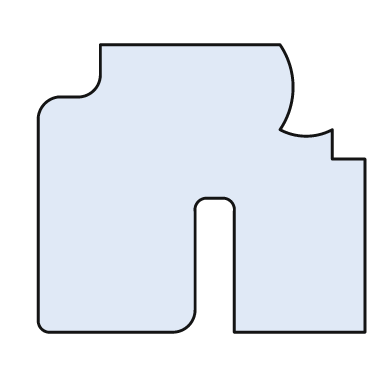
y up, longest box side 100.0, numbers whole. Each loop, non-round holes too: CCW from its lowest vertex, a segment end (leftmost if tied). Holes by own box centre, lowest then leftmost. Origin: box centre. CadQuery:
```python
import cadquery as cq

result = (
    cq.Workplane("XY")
    .moveTo(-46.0, -44.0)
    .lineTo(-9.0, -44.0)
    .threePointArc((-4.0, -42.0), (-2.0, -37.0))
    .lineTo(-2.0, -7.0)
    .threePointArc((-1.0, -4.0), (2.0, -3.0))
    .lineTo(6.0, -3.0)
    .threePointArc((9.0, -4.0), (10.0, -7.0))
    .lineTo(10.0, -44.0)
    .lineTo(50.0, -44.0)
    .lineTo(50.0, 9.0)
    .lineTo(40.0, 9.0)
    .lineTo(40.0, 18.0)
    .threePointArc((32.0, 16.0), (24.0, 18.0))
    .threePointArc((28.0, 31.0), (24.0, 44.0))
    .lineTo(-31.0, 44.0)
    .lineTo(-31.0, 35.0)
    .threePointArc((-33.0, 30.0), (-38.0, 28.0))
    .lineTo(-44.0, 28.0)
    .threePointArc((-48.0, 26.0), (-50.0, 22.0))
    .lineTo(-50.0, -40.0)
    .threePointArc((-49.0, -43.0), (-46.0, -44.0))
    .close()
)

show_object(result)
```